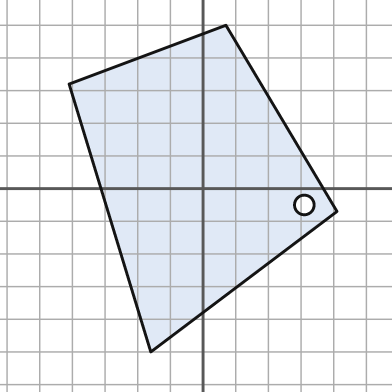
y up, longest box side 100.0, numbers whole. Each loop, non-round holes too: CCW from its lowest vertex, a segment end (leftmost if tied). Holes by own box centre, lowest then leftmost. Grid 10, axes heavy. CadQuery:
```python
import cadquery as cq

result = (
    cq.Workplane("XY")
    .moveTo(-16.0, -50.0)
    .lineTo(41.0, -7.0)
    .lineTo(7.0, 50.0)
    .lineTo(-41.0, 32.0)
    .close()
    .moveTo(31.0, -5.0)
    .circle(3.0)
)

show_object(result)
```